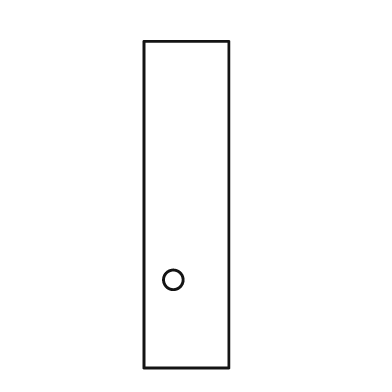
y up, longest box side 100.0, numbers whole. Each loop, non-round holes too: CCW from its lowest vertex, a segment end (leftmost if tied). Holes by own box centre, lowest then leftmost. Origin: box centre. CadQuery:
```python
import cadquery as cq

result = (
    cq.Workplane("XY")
    .moveTo(-13.0, -50.0)
    .lineTo(13.0, -50.0)
    .lineTo(13.0, 50.0)
    .lineTo(-13.0, 50.0)
    .close()
    .moveTo(-4.0, -23.0)
    .circle(3.0)
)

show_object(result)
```